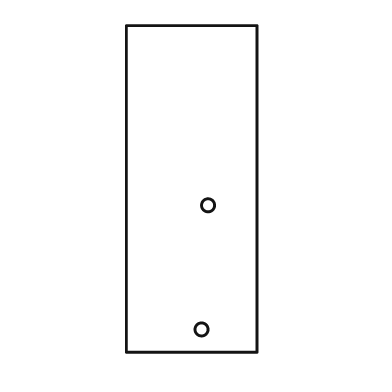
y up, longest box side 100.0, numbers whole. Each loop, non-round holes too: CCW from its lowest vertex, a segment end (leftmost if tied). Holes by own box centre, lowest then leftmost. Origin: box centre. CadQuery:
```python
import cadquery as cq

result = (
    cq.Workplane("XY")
    .moveTo(-20.0, -50.0)
    .lineTo(20.0, -50.0)
    .lineTo(20.0, 50.0)
    .lineTo(-20.0, 50.0)
    .close()
    .moveTo(3.0, -43.0)
    .circle(2.0)
    .moveTo(5.0, -5.0)
    .circle(2.0)
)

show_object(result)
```